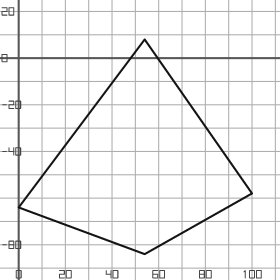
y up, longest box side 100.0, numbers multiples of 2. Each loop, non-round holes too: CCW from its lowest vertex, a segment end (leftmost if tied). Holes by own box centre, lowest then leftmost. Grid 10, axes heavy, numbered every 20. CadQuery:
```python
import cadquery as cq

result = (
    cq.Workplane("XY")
    .moveTo(54.0, -84.0)
    .lineTo(100.0, -58.0)
    .lineTo(54.0, 8.0)
    .lineTo(0.0, -64.0)
    .close()
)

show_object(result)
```